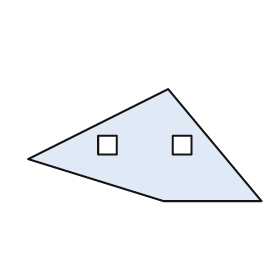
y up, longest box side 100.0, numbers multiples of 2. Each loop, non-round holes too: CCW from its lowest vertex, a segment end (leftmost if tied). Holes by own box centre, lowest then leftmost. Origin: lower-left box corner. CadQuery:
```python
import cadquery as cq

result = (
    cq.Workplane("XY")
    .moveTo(58.0, 0.0)
    .lineTo(100.0, 0.0)
    .lineTo(60.0, 48.0)
    .lineTo(0.0, 18.0)
    .close()
    .moveTo(30.0, 20.0)
    .lineTo(38.0, 20.0)
    .lineTo(38.0, 28.0)
    .lineTo(30.0, 28.0)
    .close()
    .moveTo(62.0, 20.0)
    .lineTo(70.0, 20.0)
    .lineTo(70.0, 28.0)
    .lineTo(62.0, 28.0)
    .close()
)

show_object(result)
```